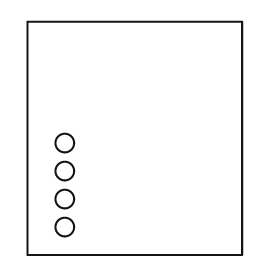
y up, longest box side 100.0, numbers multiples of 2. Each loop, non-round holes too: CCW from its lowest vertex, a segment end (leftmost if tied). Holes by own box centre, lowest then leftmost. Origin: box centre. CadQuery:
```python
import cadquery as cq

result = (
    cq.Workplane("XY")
    .moveTo(-46.0, -50.0)
    .lineTo(46.0, -50.0)
    .lineTo(46.0, 50.0)
    .lineTo(-46.0, 50.0)
    .close()
    .moveTo(-30.0, -38.0)
    .circle(4.0)
    .moveTo(-30.0, -26.0)
    .circle(4.0)
    .moveTo(-30.0, -14.0)
    .circle(4.0)
    .moveTo(-30.0, -2.0)
    .circle(4.0)
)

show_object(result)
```